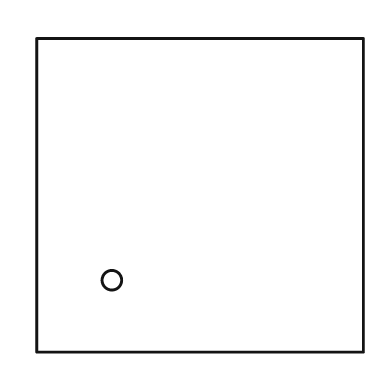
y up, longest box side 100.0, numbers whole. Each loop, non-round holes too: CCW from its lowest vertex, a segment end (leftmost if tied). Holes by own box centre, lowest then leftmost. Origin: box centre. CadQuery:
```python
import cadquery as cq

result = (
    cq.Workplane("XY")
    .moveTo(-50.0, -48.0)
    .lineTo(50.0, -48.0)
    .lineTo(50.0, 48.0)
    .lineTo(-50.0, 48.0)
    .close()
    .moveTo(-27.0, -26.0)
    .circle(3.0)
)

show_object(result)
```